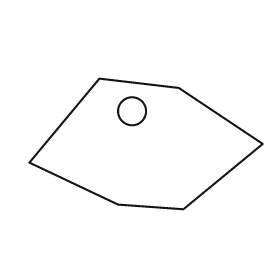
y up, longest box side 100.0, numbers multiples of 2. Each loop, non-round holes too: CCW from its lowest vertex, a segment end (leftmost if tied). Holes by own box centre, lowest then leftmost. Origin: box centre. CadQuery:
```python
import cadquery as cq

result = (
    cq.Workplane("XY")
    .moveTo(16.0, -28.0)
    .lineTo(50.0, 0.0)
    .lineTo(14.0, 24.0)
    .lineTo(-20.0, 28.0)
    .lineTo(-50.0, -8.0)
    .lineTo(-12.0, -26.0)
    .close()
    .moveTo(-6.0, 14.0)
    .circle(6.0)
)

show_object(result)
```